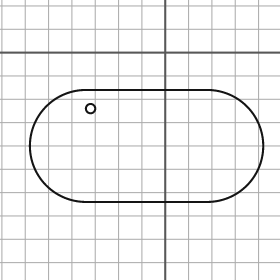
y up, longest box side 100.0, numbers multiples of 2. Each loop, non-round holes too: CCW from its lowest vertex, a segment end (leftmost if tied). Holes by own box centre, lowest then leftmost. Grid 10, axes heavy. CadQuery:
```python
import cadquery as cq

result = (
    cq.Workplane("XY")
    .moveTo(-34.0, -64.0)
    .lineTo(18.0, -64.0)
    .threePointArc((42.0, -40.0), (18.0, -16.0))
    .lineTo(-34.0, -16.0)
    .threePointArc((-58.0, -40.0), (-34.0, -64.0))
    .close()
    .moveTo(-32.0, -24.0)
    .circle(2.0)
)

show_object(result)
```